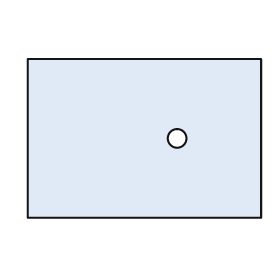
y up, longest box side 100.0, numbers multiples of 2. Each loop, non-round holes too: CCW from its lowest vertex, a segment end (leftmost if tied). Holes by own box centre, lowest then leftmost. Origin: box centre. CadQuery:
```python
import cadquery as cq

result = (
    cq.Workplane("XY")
    .moveTo(-50.0, -34.0)
    .lineTo(50.0, -34.0)
    .lineTo(50.0, 34.0)
    .lineTo(-50.0, 34.0)
    .close()
    .moveTo(14.0, 0.0)
    .circle(4.0)
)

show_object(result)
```